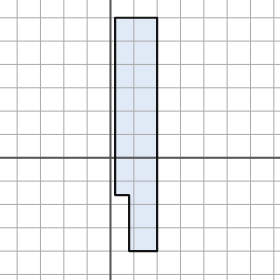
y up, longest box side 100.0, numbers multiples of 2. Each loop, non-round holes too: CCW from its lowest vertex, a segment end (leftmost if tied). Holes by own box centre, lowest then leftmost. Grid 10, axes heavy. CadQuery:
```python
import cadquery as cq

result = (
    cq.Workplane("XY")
    .moveTo(8.0, -40.0)
    .lineTo(20.0, -40.0)
    .lineTo(20.0, 60.0)
    .lineTo(2.0, 60.0)
    .lineTo(2.0, -16.0)
    .lineTo(8.0, -16.0)
    .close()
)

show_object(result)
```